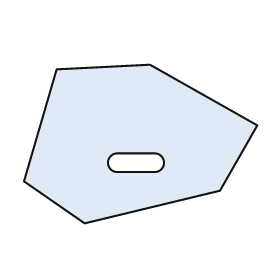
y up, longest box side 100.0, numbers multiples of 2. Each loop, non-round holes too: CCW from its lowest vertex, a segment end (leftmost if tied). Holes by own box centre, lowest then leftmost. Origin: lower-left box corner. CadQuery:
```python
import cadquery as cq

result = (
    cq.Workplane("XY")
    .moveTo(26.0, 0.0)
    .lineTo(84.0, 14.0)
    .lineTo(100.0, 42.0)
    .lineTo(54.0, 68.0)
    .lineTo(14.0, 66.0)
    .lineTo(0.0, 18.0)
    .close()
    .moveTo(40.0, 22.0)
    .lineTo(56.0, 22.0)
    .threePointArc((60.0, 26.0), (56.0, 30.0))
    .lineTo(40.0, 30.0)
    .threePointArc((36.0, 26.0), (40.0, 22.0))
    .close()
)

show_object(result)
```